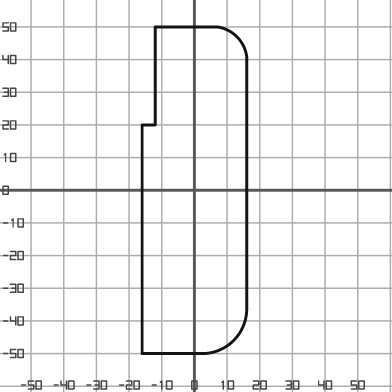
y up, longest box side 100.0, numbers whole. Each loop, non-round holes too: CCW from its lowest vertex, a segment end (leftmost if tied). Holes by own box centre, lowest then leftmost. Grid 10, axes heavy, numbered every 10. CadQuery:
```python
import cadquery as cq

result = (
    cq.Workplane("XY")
    .moveTo(-16.0, -50.0)
    .lineTo(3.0, -50.0)
    .threePointArc((12.0, -46.0), (16.0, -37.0))
    .lineTo(16.0, 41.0)
    .threePointArc((13.0, 47.0), (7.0, 50.0))
    .lineTo(-12.0, 50.0)
    .lineTo(-12.0, 20.0)
    .lineTo(-16.0, 20.0)
    .close()
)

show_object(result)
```